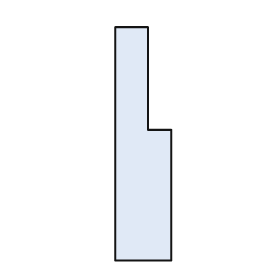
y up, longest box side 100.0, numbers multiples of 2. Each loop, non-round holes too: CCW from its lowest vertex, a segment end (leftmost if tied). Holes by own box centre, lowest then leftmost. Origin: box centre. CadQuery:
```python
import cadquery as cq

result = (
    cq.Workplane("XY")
    .moveTo(-12.0, -50.0)
    .lineTo(12.0, -50.0)
    .lineTo(12.0, 6.0)
    .lineTo(2.0, 6.0)
    .lineTo(2.0, 50.0)
    .lineTo(-12.0, 50.0)
    .close()
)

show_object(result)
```